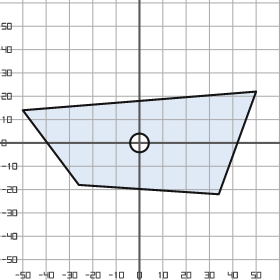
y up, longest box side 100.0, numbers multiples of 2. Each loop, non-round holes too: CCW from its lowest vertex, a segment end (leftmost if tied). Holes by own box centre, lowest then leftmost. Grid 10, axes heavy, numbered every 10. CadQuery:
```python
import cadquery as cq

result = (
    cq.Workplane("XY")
    .moveTo(34.0, -22.0)
    .lineTo(50.0, 22.0)
    .lineTo(-50.0, 14.0)
    .lineTo(-26.0, -18.0)
    .close()
    .moveTo(0.0, 0.0)
    .circle(4.0)
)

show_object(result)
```